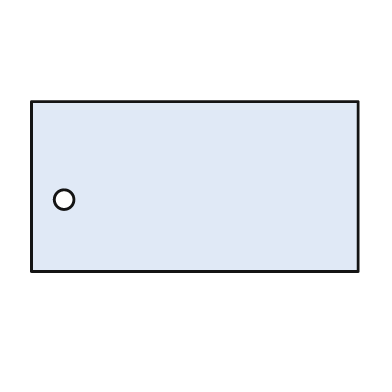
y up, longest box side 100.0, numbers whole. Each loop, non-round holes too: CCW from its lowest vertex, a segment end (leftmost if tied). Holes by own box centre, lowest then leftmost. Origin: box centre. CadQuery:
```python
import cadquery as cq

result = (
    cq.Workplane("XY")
    .moveTo(-50.0, -26.0)
    .lineTo(50.0, -26.0)
    .lineTo(50.0, 26.0)
    .lineTo(-50.0, 26.0)
    .close()
    .moveTo(-40.0, -4.0)
    .circle(3.0)
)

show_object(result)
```